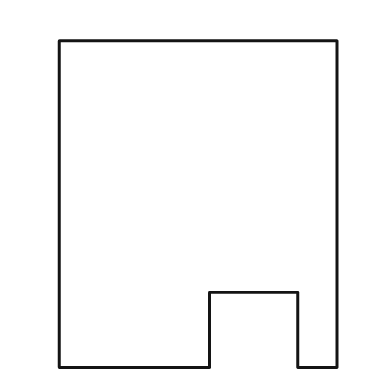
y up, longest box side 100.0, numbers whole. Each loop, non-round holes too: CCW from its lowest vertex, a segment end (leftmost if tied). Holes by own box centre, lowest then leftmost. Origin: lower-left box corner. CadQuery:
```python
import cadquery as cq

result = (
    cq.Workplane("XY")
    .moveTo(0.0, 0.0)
    .lineTo(46.0, 0.0)
    .lineTo(46.0, 23.0)
    .lineTo(73.0, 23.0)
    .lineTo(73.0, 0.0)
    .lineTo(85.0, 0.0)
    .lineTo(85.0, 100.0)
    .lineTo(0.0, 100.0)
    .close()
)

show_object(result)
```